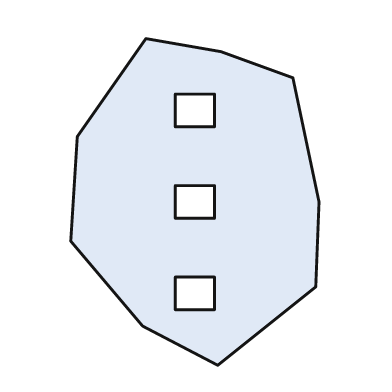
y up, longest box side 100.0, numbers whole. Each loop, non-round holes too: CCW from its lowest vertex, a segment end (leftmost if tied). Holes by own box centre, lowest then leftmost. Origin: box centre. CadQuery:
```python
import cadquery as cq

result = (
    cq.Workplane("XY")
    .moveTo(7.0, -50.0)
    .lineTo(37.0, -26.0)
    .lineTo(38.0, 0.0)
    .lineTo(30.0, 38.0)
    .lineTo(8.0, 46.0)
    .lineTo(-15.0, 50.0)
    .lineTo(-36.0, 20.0)
    .lineTo(-38.0, -12.0)
    .lineTo(-16.0, -38.0)
    .close()
    .moveTo(-6.0, -33.0)
    .lineTo(6.0, -33.0)
    .lineTo(6.0, -23.0)
    .lineTo(-6.0, -23.0)
    .close()
    .moveTo(-6.0, -5.0)
    .lineTo(6.0, -5.0)
    .lineTo(6.0, 5.0)
    .lineTo(-6.0, 5.0)
    .close()
    .moveTo(-6.0, 23.0)
    .lineTo(6.0, 23.0)
    .lineTo(6.0, 33.0)
    .lineTo(-6.0, 33.0)
    .close()
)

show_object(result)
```